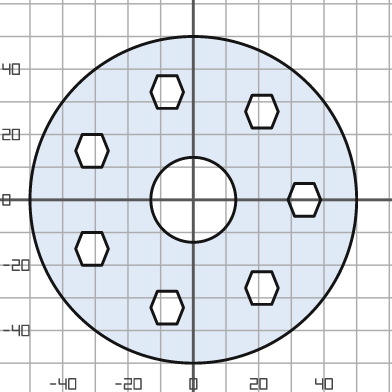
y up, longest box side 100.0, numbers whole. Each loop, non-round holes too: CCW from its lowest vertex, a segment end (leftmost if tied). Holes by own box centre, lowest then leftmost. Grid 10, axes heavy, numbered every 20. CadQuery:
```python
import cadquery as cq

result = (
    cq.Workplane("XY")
    .moveTo(0.0, 0.0)
    .circle(50.0)
    .moveTo(-11.0, -38.0)
    .lineTo(-5.0, -38.0)
    .lineTo(-3.0, -33.0)
    .lineTo(-5.0, -28.0)
    .lineTo(-11.0, -28.0)
    .lineTo(-13.0, -33.0)
    .close()
    .moveTo(18.0, -32.0)
    .lineTo(24.0, -32.0)
    .lineTo(26.0, -27.0)
    .lineTo(24.0, -22.0)
    .lineTo(18.0, -22.0)
    .lineTo(16.0, -27.0)
    .close()
    .moveTo(-34.0, -20.0)
    .lineTo(-28.0, -20.0)
    .lineTo(-26.0, -15.0)
    .lineTo(-28.0, -10.0)
    .lineTo(-34.0, -10.0)
    .lineTo(-36.0, -15.0)
    .close()
    .moveTo(0.0, 0.0)
    .circle(13.0)
    .moveTo(31.0, -5.0)
    .lineTo(37.0, -5.0)
    .lineTo(39.0, 0.0)
    .lineTo(37.0, 5.0)
    .lineTo(31.0, 5.0)
    .lineTo(29.0, 0.0)
    .close()
    .moveTo(-34.0, 10.0)
    .lineTo(-28.0, 10.0)
    .lineTo(-26.0, 15.0)
    .lineTo(-28.0, 20.0)
    .lineTo(-34.0, 20.0)
    .lineTo(-36.0, 15.0)
    .close()
    .moveTo(18.0, 22.0)
    .lineTo(24.0, 22.0)
    .lineTo(26.0, 27.0)
    .lineTo(24.0, 32.0)
    .lineTo(18.0, 32.0)
    .lineTo(16.0, 27.0)
    .close()
    .moveTo(-11.0, 28.0)
    .lineTo(-5.0, 28.0)
    .lineTo(-3.0, 33.0)
    .lineTo(-5.0, 38.0)
    .lineTo(-11.0, 38.0)
    .lineTo(-13.0, 33.0)
    .close()
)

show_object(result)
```